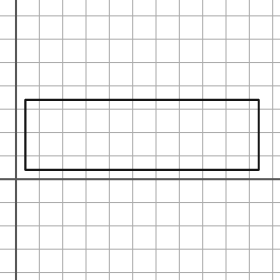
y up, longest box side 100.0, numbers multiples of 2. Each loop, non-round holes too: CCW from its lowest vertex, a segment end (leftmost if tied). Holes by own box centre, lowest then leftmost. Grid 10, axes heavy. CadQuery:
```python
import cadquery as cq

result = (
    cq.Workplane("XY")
    .moveTo(4.0, 4.0)
    .lineTo(104.0, 4.0)
    .lineTo(104.0, 34.0)
    .lineTo(4.0, 34.0)
    .close()
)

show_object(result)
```